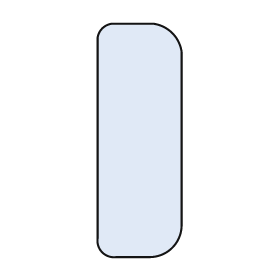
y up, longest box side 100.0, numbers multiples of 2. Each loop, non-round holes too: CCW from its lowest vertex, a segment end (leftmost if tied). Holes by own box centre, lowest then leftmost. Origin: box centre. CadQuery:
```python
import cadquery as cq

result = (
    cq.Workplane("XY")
    .moveTo(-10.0, -50.0)
    .lineTo(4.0, -50.0)
    .threePointArc((14.0, -46.0), (18.0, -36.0))
    .lineTo(18.0, 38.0)
    .threePointArc((14.0, 46.0), (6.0, 50.0))
    .lineTo(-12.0, 50.0)
    .threePointArc((-16.0, 48.0), (-18.0, 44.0))
    .lineTo(-18.0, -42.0)
    .threePointArc((-16.0, -48.0), (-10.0, -50.0))
    .close()
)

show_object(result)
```